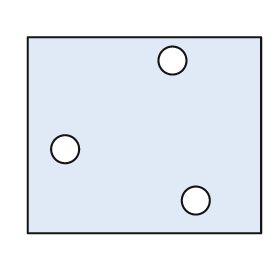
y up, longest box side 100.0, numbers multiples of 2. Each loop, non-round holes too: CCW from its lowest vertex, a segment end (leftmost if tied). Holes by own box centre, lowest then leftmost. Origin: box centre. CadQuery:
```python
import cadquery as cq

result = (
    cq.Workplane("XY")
    .moveTo(-50.0, -42.0)
    .lineTo(50.0, -42.0)
    .lineTo(50.0, 42.0)
    .lineTo(-50.0, 42.0)
    .close()
    .moveTo(22.0, -28.0)
    .circle(6.0)
    .moveTo(-34.0, -6.0)
    .circle(6.0)
    .moveTo(12.0, 32.0)
    .circle(6.0)
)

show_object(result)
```